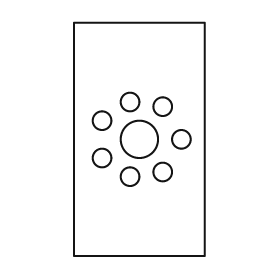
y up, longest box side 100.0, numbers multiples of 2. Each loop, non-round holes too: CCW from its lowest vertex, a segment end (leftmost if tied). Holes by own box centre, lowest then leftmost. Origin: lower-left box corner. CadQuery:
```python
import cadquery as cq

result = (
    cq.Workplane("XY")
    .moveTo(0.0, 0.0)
    .lineTo(56.0, 0.0)
    .lineTo(56.0, 100.0)
    .lineTo(0.0, 100.0)
    .close()
    .moveTo(24.0, 34.0)
    .circle(4.0)
    .moveTo(38.0, 36.0)
    .circle(4.0)
    .moveTo(12.0, 42.0)
    .circle(4.0)
    .moveTo(28.0, 50.0)
    .circle(8.0)
    .moveTo(46.0, 50.0)
    .circle(4.0)
    .moveTo(12.0, 58.0)
    .circle(4.0)
    .moveTo(38.0, 64.0)
    .circle(4.0)
    .moveTo(24.0, 66.0)
    .circle(4.0)
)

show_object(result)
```